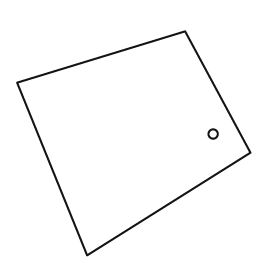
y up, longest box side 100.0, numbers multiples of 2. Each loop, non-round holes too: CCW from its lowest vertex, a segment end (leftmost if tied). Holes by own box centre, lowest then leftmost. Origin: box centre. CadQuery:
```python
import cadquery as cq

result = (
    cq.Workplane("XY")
    .moveTo(-20.0, -48.0)
    .lineTo(50.0, -4.0)
    .lineTo(22.0, 48.0)
    .lineTo(-50.0, 26.0)
    .close()
    .moveTo(34.0, 4.0)
    .circle(2.0)
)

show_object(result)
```